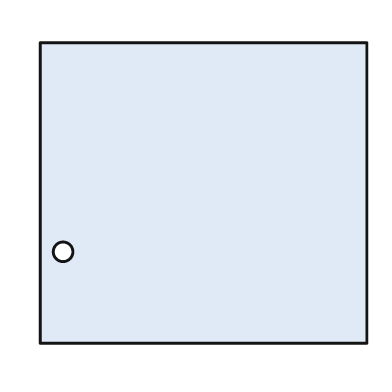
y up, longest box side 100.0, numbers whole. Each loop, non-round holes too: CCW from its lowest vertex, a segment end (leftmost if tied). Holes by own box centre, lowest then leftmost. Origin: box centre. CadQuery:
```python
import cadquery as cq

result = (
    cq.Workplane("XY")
    .moveTo(-50.0, -46.0)
    .lineTo(50.0, -46.0)
    .lineTo(50.0, 46.0)
    .lineTo(-50.0, 46.0)
    .close()
    .moveTo(-43.0, -18.0)
    .circle(3.0)
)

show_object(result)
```